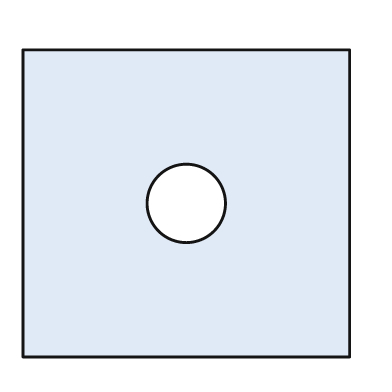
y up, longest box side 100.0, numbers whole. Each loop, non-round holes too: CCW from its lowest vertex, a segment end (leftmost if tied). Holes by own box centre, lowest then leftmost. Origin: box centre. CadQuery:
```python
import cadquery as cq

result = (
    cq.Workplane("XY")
    .moveTo(-50.0, -47.0)
    .lineTo(50.0, -47.0)
    .lineTo(50.0, 47.0)
    .lineTo(-50.0, 47.0)
    .close()
    .moveTo(0.0, 0.0)
    .circle(12.0)
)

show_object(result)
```